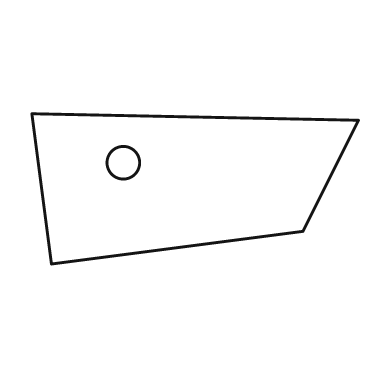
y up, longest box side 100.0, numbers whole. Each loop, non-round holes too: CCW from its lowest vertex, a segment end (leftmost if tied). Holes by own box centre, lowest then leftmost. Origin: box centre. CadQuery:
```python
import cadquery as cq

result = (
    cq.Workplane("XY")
    .moveTo(-44.0, -23.0)
    .lineTo(33.0, -13.0)
    .lineTo(50.0, 21.0)
    .lineTo(-50.0, 23.0)
    .close()
    .moveTo(-22.0, 8.0)
    .circle(5.0)
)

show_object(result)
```